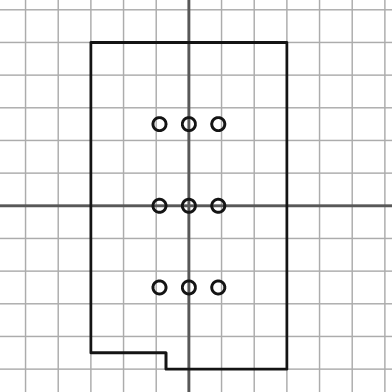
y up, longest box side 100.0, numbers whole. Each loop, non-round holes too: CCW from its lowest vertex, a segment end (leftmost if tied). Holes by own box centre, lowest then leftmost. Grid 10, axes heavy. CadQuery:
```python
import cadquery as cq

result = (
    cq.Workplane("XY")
    .moveTo(-7.0, -50.0)
    .lineTo(30.0, -50.0)
    .lineTo(30.0, 50.0)
    .lineTo(-30.0, 50.0)
    .lineTo(-30.0, -45.0)
    .lineTo(-7.0, -45.0)
    .close()
    .moveTo(-9.0, -25.0)
    .circle(2.0)
    .moveTo(0.0, -25.0)
    .circle(2.0)
    .moveTo(9.0, -25.0)
    .circle(2.0)
    .moveTo(-9.0, 0.0)
    .circle(2.0)
    .moveTo(0.0, 0.0)
    .circle(2.0)
    .moveTo(9.0, 0.0)
    .circle(2.0)
    .moveTo(-9.0, 25.0)
    .circle(2.0)
    .moveTo(0.0, 25.0)
    .circle(2.0)
    .moveTo(9.0, 25.0)
    .circle(2.0)
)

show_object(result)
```